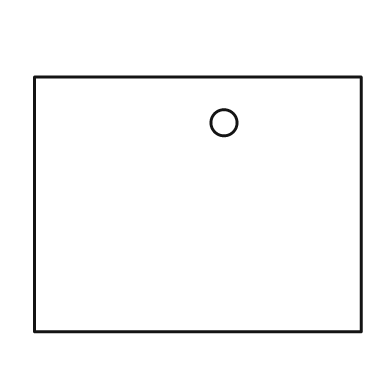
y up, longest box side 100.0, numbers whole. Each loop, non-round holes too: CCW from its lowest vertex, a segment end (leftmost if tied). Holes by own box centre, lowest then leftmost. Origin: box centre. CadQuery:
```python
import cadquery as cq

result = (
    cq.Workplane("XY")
    .moveTo(-50.0, -39.0)
    .lineTo(50.0, -39.0)
    .lineTo(50.0, 39.0)
    .lineTo(-50.0, 39.0)
    .close()
    .moveTo(8.0, 25.0)
    .circle(4.0)
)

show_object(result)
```